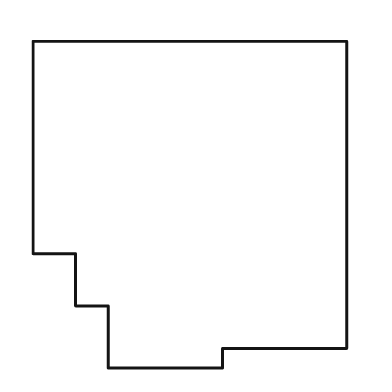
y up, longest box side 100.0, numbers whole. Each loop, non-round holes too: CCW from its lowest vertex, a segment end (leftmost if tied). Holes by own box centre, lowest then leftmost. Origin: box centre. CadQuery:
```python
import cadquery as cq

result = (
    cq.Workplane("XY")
    .moveTo(-25.0, -50.0)
    .lineTo(10.0, -50.0)
    .lineTo(10.0, -44.0)
    .lineTo(48.0, -44.0)
    .lineTo(48.0, 50.0)
    .lineTo(-48.0, 50.0)
    .lineTo(-48.0, -15.0)
    .lineTo(-35.0, -15.0)
    .lineTo(-35.0, -31.0)
    .lineTo(-25.0, -31.0)
    .close()
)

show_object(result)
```